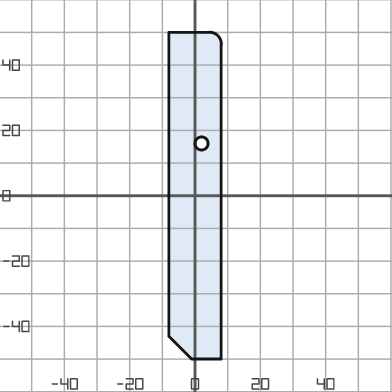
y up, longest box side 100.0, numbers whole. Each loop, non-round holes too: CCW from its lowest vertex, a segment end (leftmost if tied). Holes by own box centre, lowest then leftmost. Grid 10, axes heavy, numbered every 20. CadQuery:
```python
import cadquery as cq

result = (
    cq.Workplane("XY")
    .moveTo(-1.0, -50.0)
    .lineTo(8.0, -50.0)
    .lineTo(8.0, 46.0)
    .threePointArc((7.0, 49.0), (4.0, 50.0))
    .lineTo(-8.0, 50.0)
    .lineTo(-8.0, -43.0)
    .close()
    .moveTo(2.0, 16.0)
    .circle(2.0)
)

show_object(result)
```